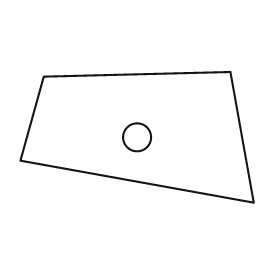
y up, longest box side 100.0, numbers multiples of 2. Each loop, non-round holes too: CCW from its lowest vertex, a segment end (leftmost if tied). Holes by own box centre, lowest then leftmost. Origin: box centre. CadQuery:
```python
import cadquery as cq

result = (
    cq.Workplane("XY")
    .moveTo(50.0, -28.0)
    .lineTo(40.0, 28.0)
    .lineTo(-40.0, 26.0)
    .lineTo(-50.0, -10.0)
    .close()
    .moveTo(0.0, 0.0)
    .circle(6.0)
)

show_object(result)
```